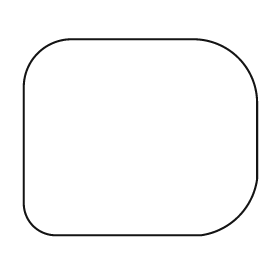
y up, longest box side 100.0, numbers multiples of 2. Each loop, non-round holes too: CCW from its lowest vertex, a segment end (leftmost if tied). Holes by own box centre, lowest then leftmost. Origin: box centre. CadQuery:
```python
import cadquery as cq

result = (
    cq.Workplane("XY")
    .moveTo(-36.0, -42.0)
    .lineTo(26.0, -42.0)
    .threePointArc((42.0, -34.0), (50.0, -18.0))
    .lineTo(50.0, 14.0)
    .threePointArc((42.0, 34.0), (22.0, 42.0))
    .lineTo(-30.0, 42.0)
    .threePointArc((-44.0, 36.0), (-50.0, 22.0))
    .lineTo(-50.0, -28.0)
    .threePointArc((-46.0, -38.0), (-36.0, -42.0))
    .close()
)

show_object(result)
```